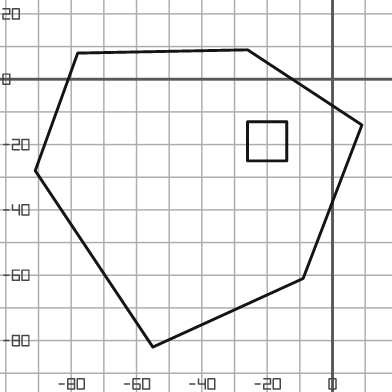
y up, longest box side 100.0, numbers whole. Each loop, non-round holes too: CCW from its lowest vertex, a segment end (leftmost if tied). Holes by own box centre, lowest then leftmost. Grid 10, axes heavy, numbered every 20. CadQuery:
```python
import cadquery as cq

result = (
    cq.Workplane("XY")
    .moveTo(-55.0, -82.0)
    .lineTo(-9.0, -61.0)
    .lineTo(9.0, -14.0)
    .lineTo(-26.0, 9.0)
    .lineTo(-78.0, 8.0)
    .lineTo(-91.0, -28.0)
    .close()
    .moveTo(-26.0, -25.0)
    .lineTo(-14.0, -25.0)
    .lineTo(-14.0, -13.0)
    .lineTo(-26.0, -13.0)
    .close()
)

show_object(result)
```